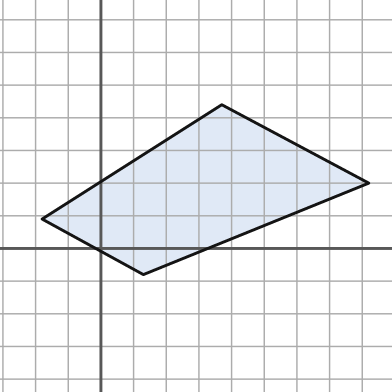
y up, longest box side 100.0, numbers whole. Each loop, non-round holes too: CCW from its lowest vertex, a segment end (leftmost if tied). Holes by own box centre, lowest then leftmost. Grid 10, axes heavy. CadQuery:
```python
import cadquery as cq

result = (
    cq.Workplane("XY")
    .moveTo(13.0, -8.0)
    .lineTo(82.0, 20.0)
    .lineTo(37.0, 44.0)
    .lineTo(-18.0, 9.0)
    .close()
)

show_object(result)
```